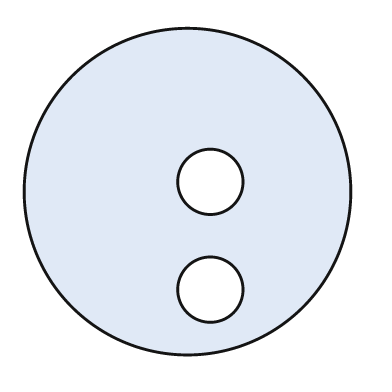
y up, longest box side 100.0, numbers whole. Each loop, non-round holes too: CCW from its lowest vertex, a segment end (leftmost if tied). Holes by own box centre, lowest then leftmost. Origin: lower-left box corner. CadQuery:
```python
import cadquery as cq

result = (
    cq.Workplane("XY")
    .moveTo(50.0, 50.0)
    .circle(50.0)
    .moveTo(57.0, 20.0)
    .circle(10.0)
    .moveTo(57.0, 53.0)
    .circle(10.0)
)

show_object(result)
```